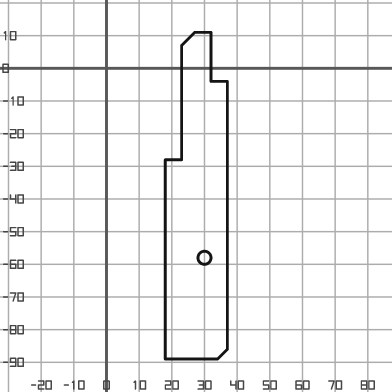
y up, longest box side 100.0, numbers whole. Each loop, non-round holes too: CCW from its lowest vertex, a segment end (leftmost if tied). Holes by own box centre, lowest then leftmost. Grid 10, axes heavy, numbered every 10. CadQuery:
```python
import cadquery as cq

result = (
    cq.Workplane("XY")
    .moveTo(18.0, -89.0)
    .lineTo(34.0, -89.0)
    .lineTo(37.0, -86.0)
    .lineTo(37.0, -4.0)
    .lineTo(32.0, -4.0)
    .lineTo(32.0, 11.0)
    .lineTo(27.0, 11.0)
    .lineTo(23.0, 7.0)
    .lineTo(23.0, -28.0)
    .lineTo(18.0, -28.0)
    .close()
    .moveTo(30.0, -58.0)
    .circle(2.0)
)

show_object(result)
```